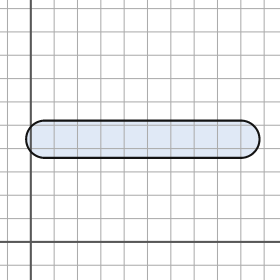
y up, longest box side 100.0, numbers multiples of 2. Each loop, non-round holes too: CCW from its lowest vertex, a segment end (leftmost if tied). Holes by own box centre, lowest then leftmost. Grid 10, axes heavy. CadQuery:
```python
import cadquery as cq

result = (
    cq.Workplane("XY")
    .moveTo(6.0, 36.0)
    .lineTo(90.0, 36.0)
    .threePointArc((98.0, 44.0), (90.0, 52.0))
    .lineTo(6.0, 52.0)
    .threePointArc((-2.0, 44.0), (6.0, 36.0))
    .close()
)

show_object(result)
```